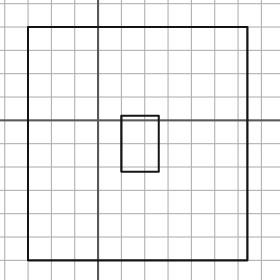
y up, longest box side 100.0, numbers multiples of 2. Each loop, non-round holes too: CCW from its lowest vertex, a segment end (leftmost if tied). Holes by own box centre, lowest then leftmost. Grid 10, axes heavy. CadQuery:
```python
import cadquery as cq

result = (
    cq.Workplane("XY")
    .moveTo(-30.0, -60.0)
    .lineTo(64.0, -60.0)
    .lineTo(64.0, 40.0)
    .lineTo(-30.0, 40.0)
    .close()
    .moveTo(10.0, -22.0)
    .lineTo(26.0, -22.0)
    .lineTo(26.0, 2.0)
    .lineTo(10.0, 2.0)
    .close()
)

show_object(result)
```